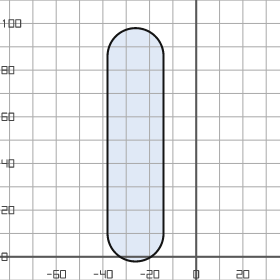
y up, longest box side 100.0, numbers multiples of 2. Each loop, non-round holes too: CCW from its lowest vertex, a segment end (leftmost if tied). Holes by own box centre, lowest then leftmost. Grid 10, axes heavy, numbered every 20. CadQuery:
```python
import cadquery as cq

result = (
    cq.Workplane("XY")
    .moveTo(-38.0, 10.0)
    .threePointArc((-26.0, -2.0), (-14.0, 10.0))
    .lineTo(-14.0, 86.0)
    .threePointArc((-26.0, 98.0), (-38.0, 86.0))
    .close()
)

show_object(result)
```